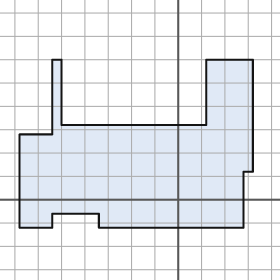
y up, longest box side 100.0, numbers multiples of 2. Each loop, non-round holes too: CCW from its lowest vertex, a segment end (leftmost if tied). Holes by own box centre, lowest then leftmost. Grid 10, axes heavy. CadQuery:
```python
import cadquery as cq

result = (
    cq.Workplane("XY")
    .moveTo(-68.0, -12.0)
    .lineTo(-54.0, -12.0)
    .lineTo(-54.0, -6.0)
    .lineTo(-34.0, -6.0)
    .lineTo(-34.0, -12.0)
    .lineTo(28.0, -12.0)
    .lineTo(28.0, 12.0)
    .lineTo(32.0, 12.0)
    .lineTo(32.0, 60.0)
    .lineTo(12.0, 60.0)
    .lineTo(12.0, 32.0)
    .lineTo(-50.0, 32.0)
    .lineTo(-50.0, 60.0)
    .lineTo(-54.0, 60.0)
    .lineTo(-54.0, 28.0)
    .lineTo(-68.0, 28.0)
    .close()
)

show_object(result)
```